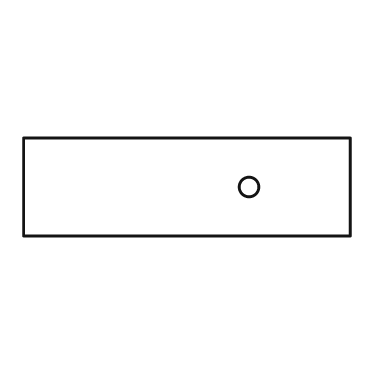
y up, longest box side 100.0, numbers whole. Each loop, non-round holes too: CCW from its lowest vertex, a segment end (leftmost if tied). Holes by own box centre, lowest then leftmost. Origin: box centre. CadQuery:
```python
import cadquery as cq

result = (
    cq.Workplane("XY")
    .moveTo(-50.0, -15.0)
    .lineTo(50.0, -15.0)
    .lineTo(50.0, 15.0)
    .lineTo(-50.0, 15.0)
    .close()
    .moveTo(19.0, 0.0)
    .circle(3.0)
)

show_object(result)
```